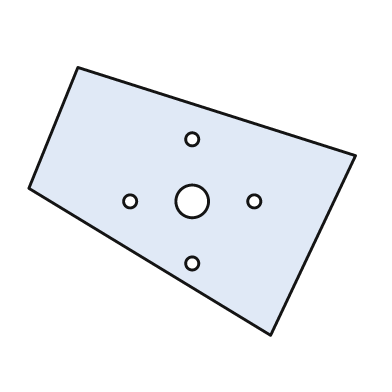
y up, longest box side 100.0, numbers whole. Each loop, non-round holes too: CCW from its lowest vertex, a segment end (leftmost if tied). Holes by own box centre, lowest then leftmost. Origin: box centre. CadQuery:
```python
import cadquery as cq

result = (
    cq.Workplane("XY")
    .moveTo(24.0, -41.0)
    .lineTo(50.0, 14.0)
    .lineTo(-35.0, 41.0)
    .lineTo(-50.0, 4.0)
    .close()
    .moveTo(0.0, -19.0)
    .circle(2.0)
    .moveTo(-19.0, 0.0)
    .circle(2.0)
    .moveTo(0.0, 0.0)
    .circle(5.0)
    .moveTo(19.0, 0.0)
    .circle(2.0)
    .moveTo(0.0, 19.0)
    .circle(2.0)
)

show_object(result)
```